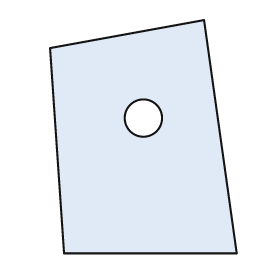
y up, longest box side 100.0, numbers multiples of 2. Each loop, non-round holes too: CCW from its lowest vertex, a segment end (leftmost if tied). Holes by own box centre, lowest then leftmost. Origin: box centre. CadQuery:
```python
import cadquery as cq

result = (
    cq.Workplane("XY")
    .moveTo(-34.0, -50.0)
    .lineTo(40.0, -50.0)
    .lineTo(26.0, 50.0)
    .lineTo(-40.0, 38.0)
    .close()
    .moveTo(0.0, 8.0)
    .circle(8.0)
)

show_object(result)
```